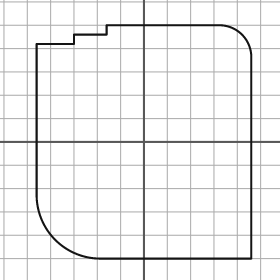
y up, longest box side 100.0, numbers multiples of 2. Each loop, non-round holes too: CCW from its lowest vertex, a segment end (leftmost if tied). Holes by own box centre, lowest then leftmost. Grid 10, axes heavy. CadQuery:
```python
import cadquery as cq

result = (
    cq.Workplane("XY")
    .moveTo(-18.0, -50.0)
    .lineTo(46.0, -50.0)
    .lineTo(46.0, 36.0)
    .threePointArc((42.0, 46.0), (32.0, 50.0))
    .lineTo(-16.0, 50.0)
    .lineTo(-16.0, 46.0)
    .lineTo(-30.0, 46.0)
    .lineTo(-30.0, 42.0)
    .lineTo(-46.0, 42.0)
    .lineTo(-46.0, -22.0)
    .threePointArc((-38.0, -42.0), (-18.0, -50.0))
    .close()
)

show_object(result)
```